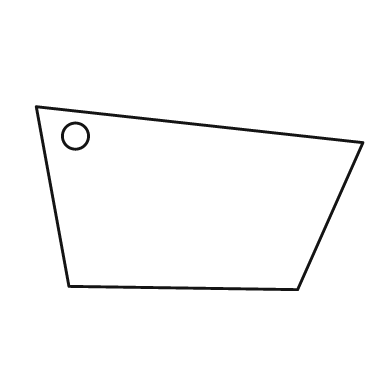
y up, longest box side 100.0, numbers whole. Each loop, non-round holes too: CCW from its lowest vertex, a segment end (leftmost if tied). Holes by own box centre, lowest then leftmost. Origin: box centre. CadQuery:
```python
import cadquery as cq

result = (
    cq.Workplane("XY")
    .moveTo(30.0, -28.0)
    .lineTo(50.0, 17.0)
    .lineTo(-50.0, 28.0)
    .lineTo(-40.0, -27.0)
    .close()
    .moveTo(-38.0, 19.0)
    .circle(4.0)
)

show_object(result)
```